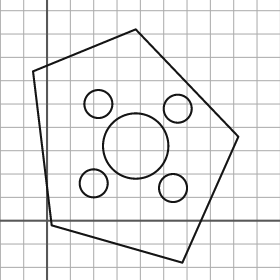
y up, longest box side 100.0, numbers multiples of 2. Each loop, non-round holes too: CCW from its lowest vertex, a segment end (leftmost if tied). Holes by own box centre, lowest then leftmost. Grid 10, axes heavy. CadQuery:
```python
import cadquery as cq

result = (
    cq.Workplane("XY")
    .moveTo(58.0, -18.0)
    .lineTo(82.0, 36.0)
    .lineTo(38.0, 82.0)
    .lineTo(-6.0, 64.0)
    .lineTo(2.0, -2.0)
    .close()
    .moveTo(54.0, 14.0)
    .circle(6.0)
    .moveTo(20.0, 16.0)
    .circle(6.0)
    .moveTo(38.0, 32.0)
    .circle(14.0)
    .moveTo(56.0, 48.0)
    .circle(6.0)
    .moveTo(22.0, 50.0)
    .circle(6.0)
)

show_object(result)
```